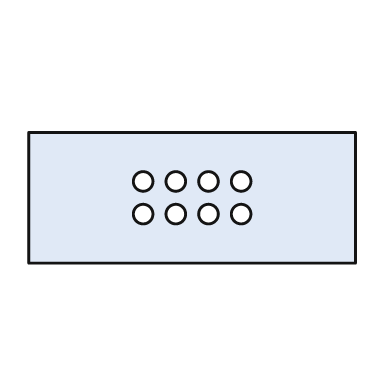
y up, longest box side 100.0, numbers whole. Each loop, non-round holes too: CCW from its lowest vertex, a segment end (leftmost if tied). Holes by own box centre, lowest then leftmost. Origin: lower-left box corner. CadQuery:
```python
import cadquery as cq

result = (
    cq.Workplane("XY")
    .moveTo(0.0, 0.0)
    .lineTo(100.0, 0.0)
    .lineTo(100.0, 40.0)
    .lineTo(0.0, 40.0)
    .close()
    .moveTo(35.0, 15.0)
    .circle(3.0)
    .moveTo(45.0, 15.0)
    .circle(3.0)
    .moveTo(55.0, 15.0)
    .circle(3.0)
    .moveTo(65.0, 15.0)
    .circle(3.0)
    .moveTo(35.0, 25.0)
    .circle(3.0)
    .moveTo(45.0, 25.0)
    .circle(3.0)
    .moveTo(55.0, 25.0)
    .circle(3.0)
    .moveTo(65.0, 25.0)
    .circle(3.0)
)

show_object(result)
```